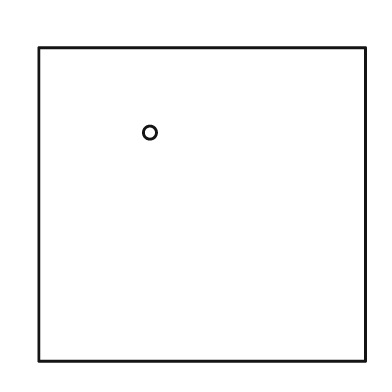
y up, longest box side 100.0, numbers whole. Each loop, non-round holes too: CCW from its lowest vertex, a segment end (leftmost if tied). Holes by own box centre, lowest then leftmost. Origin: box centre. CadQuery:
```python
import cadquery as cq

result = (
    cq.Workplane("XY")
    .moveTo(-50.0, -48.0)
    .lineTo(50.0, -48.0)
    .lineTo(50.0, 48.0)
    .lineTo(-50.0, 48.0)
    .close()
    .moveTo(-16.0, 22.0)
    .circle(2.0)
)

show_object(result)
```